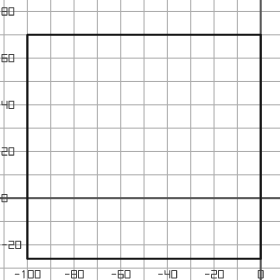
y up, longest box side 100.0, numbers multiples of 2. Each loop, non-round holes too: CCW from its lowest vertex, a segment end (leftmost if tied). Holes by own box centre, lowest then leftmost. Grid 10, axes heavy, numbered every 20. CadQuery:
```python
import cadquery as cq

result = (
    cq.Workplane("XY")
    .moveTo(-100.0, -26.0)
    .lineTo(0.0, -26.0)
    .lineTo(0.0, 70.0)
    .lineTo(-100.0, 70.0)
    .close()
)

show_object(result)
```